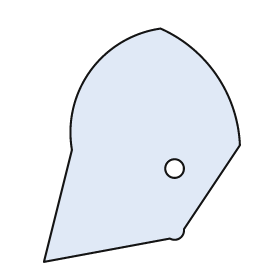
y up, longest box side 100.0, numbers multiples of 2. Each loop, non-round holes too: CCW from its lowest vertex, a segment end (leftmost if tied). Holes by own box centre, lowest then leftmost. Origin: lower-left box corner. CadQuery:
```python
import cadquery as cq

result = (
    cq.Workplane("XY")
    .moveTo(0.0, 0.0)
    .lineTo(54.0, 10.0)
    .threePointArc((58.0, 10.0), (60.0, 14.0))
    .lineTo(84.0, 50.0)
    .threePointArc((74.0, 80.0), (50.0, 100.0))
    .threePointArc((20.0, 82.0), (12.0, 48.0))
    .close()
    .moveTo(56.0, 40.0)
    .circle(4.0)
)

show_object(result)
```